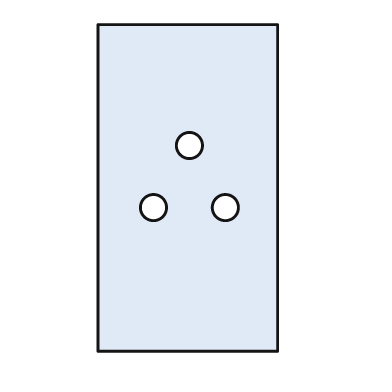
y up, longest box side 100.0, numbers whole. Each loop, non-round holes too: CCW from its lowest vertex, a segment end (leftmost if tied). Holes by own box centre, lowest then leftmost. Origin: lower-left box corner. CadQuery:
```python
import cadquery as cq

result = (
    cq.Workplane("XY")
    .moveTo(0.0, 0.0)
    .lineTo(55.0, 0.0)
    .lineTo(55.0, 100.0)
    .lineTo(0.0, 100.0)
    .close()
    .moveTo(17.0, 44.0)
    .circle(4.0)
    .moveTo(39.0, 44.0)
    .circle(4.0)
    .moveTo(28.0, 63.0)
    .circle(4.0)
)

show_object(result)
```